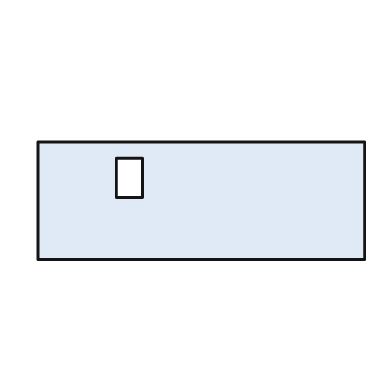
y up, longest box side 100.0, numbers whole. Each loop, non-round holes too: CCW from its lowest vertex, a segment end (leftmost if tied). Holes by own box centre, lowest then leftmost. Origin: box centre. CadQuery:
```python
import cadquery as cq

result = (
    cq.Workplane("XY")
    .moveTo(-50.0, -18.0)
    .lineTo(50.0, -18.0)
    .lineTo(50.0, 18.0)
    .lineTo(-50.0, 18.0)
    .close()
    .moveTo(-26.0, 1.0)
    .lineTo(-18.0, 1.0)
    .lineTo(-18.0, 13.0)
    .lineTo(-26.0, 13.0)
    .close()
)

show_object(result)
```